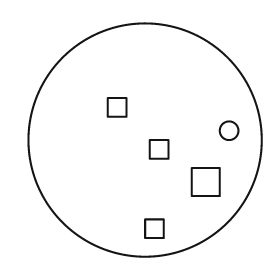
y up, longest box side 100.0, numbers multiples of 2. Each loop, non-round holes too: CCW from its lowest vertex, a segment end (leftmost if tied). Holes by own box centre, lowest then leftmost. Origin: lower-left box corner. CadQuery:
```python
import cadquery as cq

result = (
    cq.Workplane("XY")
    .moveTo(50.0, 50.0)
    .circle(50.0)
    .moveTo(50.0, 8.0)
    .lineTo(58.0, 8.0)
    .lineTo(58.0, 16.0)
    .lineTo(50.0, 16.0)
    .close()
    .moveTo(70.0, 26.0)
    .lineTo(82.0, 26.0)
    .lineTo(82.0, 38.0)
    .lineTo(70.0, 38.0)
    .close()
    .moveTo(52.0, 42.0)
    .lineTo(60.0, 42.0)
    .lineTo(60.0, 50.0)
    .lineTo(52.0, 50.0)
    .close()
    .moveTo(86.0, 54.0)
    .circle(4.0)
    .moveTo(34.0, 60.0)
    .lineTo(42.0, 60.0)
    .lineTo(42.0, 68.0)
    .lineTo(34.0, 68.0)
    .close()
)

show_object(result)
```